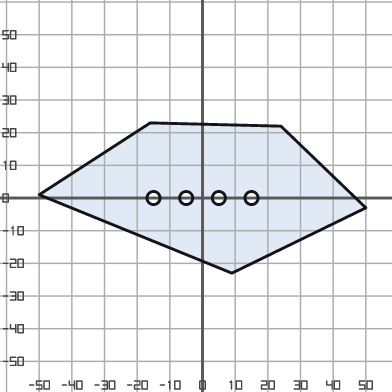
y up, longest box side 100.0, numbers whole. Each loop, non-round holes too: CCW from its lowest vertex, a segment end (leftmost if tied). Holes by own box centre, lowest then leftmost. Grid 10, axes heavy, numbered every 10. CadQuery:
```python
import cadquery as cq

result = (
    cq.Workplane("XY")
    .moveTo(9.0, -23.0)
    .lineTo(50.0, -3.0)
    .lineTo(24.0, 22.0)
    .lineTo(-16.0, 23.0)
    .lineTo(-50.0, 1.0)
    .close()
    .moveTo(-15.0, 0.0)
    .circle(2.0)
    .moveTo(-5.0, 0.0)
    .circle(2.0)
    .moveTo(5.0, 0.0)
    .circle(2.0)
    .moveTo(15.0, 0.0)
    .circle(2.0)
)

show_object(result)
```